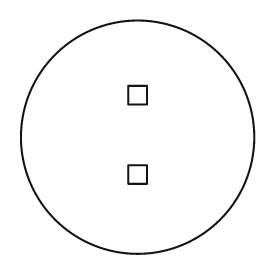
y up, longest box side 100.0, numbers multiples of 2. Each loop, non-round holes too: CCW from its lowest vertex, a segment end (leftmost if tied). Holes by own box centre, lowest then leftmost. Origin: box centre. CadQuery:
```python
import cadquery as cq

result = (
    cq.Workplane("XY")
    .moveTo(0.0, 0.0)
    .circle(50.0)
    .moveTo(-4.0, -20.0)
    .lineTo(4.0, -20.0)
    .lineTo(4.0, -12.0)
    .lineTo(-4.0, -12.0)
    .close()
    .moveTo(-4.0, 14.0)
    .lineTo(4.0, 14.0)
    .lineTo(4.0, 22.0)
    .lineTo(-4.0, 22.0)
    .close()
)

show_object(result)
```